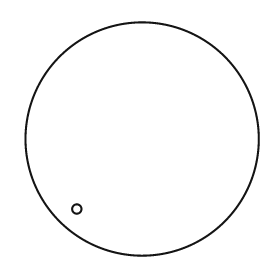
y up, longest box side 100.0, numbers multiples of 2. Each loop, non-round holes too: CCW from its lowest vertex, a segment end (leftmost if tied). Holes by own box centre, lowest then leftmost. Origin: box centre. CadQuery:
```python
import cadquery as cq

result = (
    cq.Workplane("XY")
    .moveTo(0.0, 0.0)
    .circle(50.0)
    .moveTo(-28.0, -30.0)
    .circle(2.0)
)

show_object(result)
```